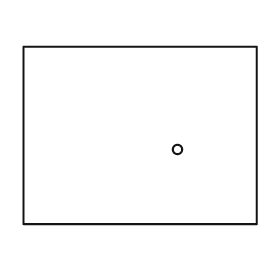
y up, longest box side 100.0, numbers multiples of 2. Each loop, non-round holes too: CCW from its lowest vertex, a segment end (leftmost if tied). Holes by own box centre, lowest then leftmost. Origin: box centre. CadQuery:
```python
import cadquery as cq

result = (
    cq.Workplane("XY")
    .moveTo(-50.0, -38.0)
    .lineTo(50.0, -38.0)
    .lineTo(50.0, 38.0)
    .lineTo(-50.0, 38.0)
    .close()
    .moveTo(16.0, -6.0)
    .circle(2.0)
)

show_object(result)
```